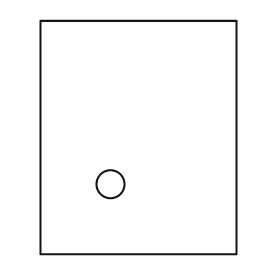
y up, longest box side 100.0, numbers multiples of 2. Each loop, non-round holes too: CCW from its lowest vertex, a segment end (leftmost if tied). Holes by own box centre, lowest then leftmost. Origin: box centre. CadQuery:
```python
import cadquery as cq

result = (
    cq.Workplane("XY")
    .moveTo(-42.0, -50.0)
    .lineTo(42.0, -50.0)
    .lineTo(42.0, 50.0)
    .lineTo(-42.0, 50.0)
    .close()
    .moveTo(-12.0, -20.0)
    .circle(6.0)
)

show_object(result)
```